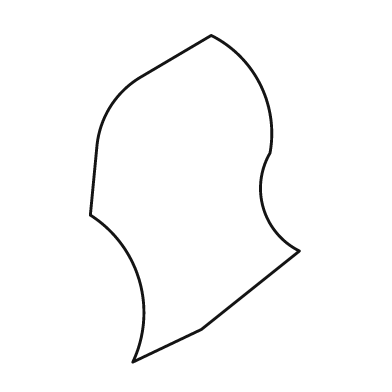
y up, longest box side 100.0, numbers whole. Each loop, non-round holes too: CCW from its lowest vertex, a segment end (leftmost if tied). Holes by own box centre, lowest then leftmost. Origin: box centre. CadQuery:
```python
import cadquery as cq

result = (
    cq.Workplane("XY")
    .moveTo(-19.0, -50.0)
    .lineTo(2.0, -40.0)
    .lineTo(32.0, -16.0)
    .threePointArc((21.0, -3.0), (23.0, 14.0))
    .threePointArc((20.0, 35.0), (5.0, 50.0))
    .lineTo(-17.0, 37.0)
    .threePointArc((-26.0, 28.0), (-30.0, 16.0))
    .lineTo(-32.0, -5.0)
    .threePointArc((-17.0, -25.0), (-19.0, -50.0))
    .close()
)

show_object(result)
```